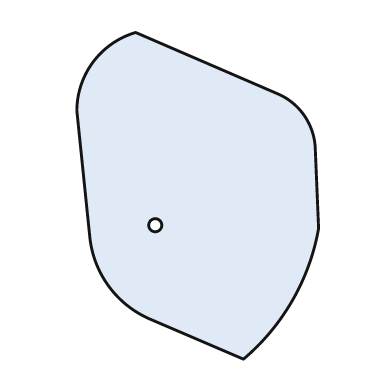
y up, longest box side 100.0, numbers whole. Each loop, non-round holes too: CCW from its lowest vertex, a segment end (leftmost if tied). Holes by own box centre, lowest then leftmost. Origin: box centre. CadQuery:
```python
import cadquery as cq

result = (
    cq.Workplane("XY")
    .moveTo(14.0, -50.0)
    .threePointArc((29.0, -32.0), (37.0, -10.0))
    .lineTo(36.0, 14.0)
    .threePointArc((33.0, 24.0), (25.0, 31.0))
    .lineTo(-19.0, 50.0)
    .threePointArc((-32.0, 41.0), (-37.0, 26.0))
    .lineTo(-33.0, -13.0)
    .threePointArc((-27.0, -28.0), (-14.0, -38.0))
    .close()
    .moveTo(-13.0, -9.0)
    .circle(2.0)
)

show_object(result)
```